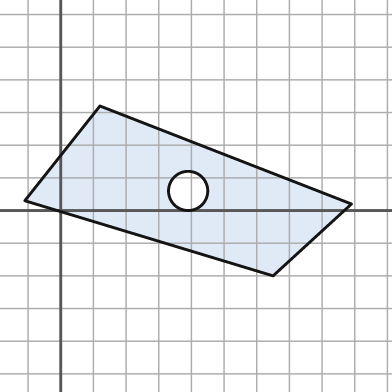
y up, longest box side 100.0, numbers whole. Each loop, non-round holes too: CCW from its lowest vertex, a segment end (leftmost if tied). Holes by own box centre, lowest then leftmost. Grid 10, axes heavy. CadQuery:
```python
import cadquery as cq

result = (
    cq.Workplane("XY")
    .moveTo(65.0, -20.0)
    .lineTo(89.0, 2.0)
    .lineTo(12.0, 32.0)
    .lineTo(-11.0, 3.0)
    .close()
    .moveTo(39.0, 6.0)
    .circle(6.0)
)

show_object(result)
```